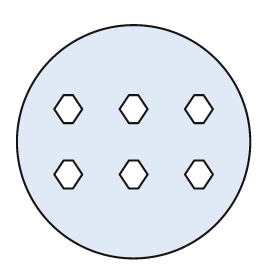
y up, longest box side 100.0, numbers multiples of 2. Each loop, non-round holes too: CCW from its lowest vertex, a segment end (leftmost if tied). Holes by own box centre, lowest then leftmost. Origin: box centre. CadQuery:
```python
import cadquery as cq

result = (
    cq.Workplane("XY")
    .moveTo(0.0, 0.0)
    .circle(50.0)
    .moveTo(-30.0, -20.0)
    .lineTo(-26.0, -20.0)
    .lineTo(-22.0, -14.0)
    .lineTo(-26.0, -8.0)
    .lineTo(-30.0, -8.0)
    .lineTo(-34.0, -14.0)
    .close()
    .moveTo(-2.0, -20.0)
    .lineTo(2.0, -20.0)
    .lineTo(6.0, -14.0)
    .lineTo(2.0, -8.0)
    .lineTo(-2.0, -8.0)
    .lineTo(-6.0, -14.0)
    .close()
    .moveTo(26.0, -20.0)
    .lineTo(30.0, -20.0)
    .lineTo(34.0, -14.0)
    .lineTo(30.0, -8.0)
    .lineTo(26.0, -8.0)
    .lineTo(22.0, -14.0)
    .close()
    .moveTo(-30.0, 8.0)
    .lineTo(-26.0, 8.0)
    .lineTo(-22.0, 14.0)
    .lineTo(-26.0, 20.0)
    .lineTo(-30.0, 20.0)
    .lineTo(-34.0, 14.0)
    .close()
    .moveTo(-2.0, 8.0)
    .lineTo(2.0, 8.0)
    .lineTo(6.0, 14.0)
    .lineTo(2.0, 20.0)
    .lineTo(-2.0, 20.0)
    .lineTo(-6.0, 14.0)
    .close()
    .moveTo(26.0, 8.0)
    .lineTo(30.0, 8.0)
    .lineTo(34.0, 14.0)
    .lineTo(30.0, 20.0)
    .lineTo(26.0, 20.0)
    .lineTo(22.0, 14.0)
    .close()
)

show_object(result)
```